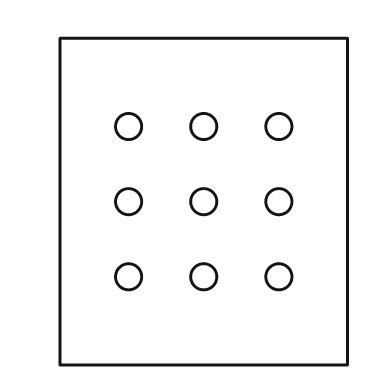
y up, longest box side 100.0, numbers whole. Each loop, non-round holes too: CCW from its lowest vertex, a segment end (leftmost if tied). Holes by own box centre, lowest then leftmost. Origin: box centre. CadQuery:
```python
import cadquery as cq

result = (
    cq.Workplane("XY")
    .moveTo(-44.0, -50.0)
    .lineTo(44.0, -50.0)
    .lineTo(44.0, 50.0)
    .lineTo(-44.0, 50.0)
    .close()
    .moveTo(-23.0, -23.0)
    .circle(4.0)
    .moveTo(0.0, -23.0)
    .circle(4.0)
    .moveTo(23.0, -23.0)
    .circle(4.0)
    .moveTo(-23.0, 0.0)
    .circle(4.0)
    .moveTo(0.0, 0.0)
    .circle(4.0)
    .moveTo(23.0, 0.0)
    .circle(4.0)
    .moveTo(-23.0, 23.0)
    .circle(4.0)
    .moveTo(0.0, 23.0)
    .circle(4.0)
    .moveTo(23.0, 23.0)
    .circle(4.0)
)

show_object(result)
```